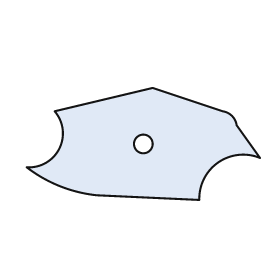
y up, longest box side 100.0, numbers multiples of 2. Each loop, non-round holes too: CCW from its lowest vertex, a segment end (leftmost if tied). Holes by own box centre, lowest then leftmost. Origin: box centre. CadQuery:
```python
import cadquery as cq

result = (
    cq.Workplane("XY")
    .moveTo(24.0, -24.0)
    .threePointArc((32.0, -8.0), (50.0, -6.0))
    .lineTo(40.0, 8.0)
    .threePointArc((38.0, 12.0), (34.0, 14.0))
    .lineTo(4.0, 24.0)
    .lineTo(-38.0, 14.0)
    .threePointArc((-36.0, -2.0), (-50.0, -10.0))
    .threePointArc((-36.0, -18.0), (-20.0, -22.0))
    .close()
    .moveTo(0.0, 0.0)
    .circle(4.0)
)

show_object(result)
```